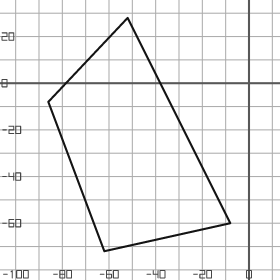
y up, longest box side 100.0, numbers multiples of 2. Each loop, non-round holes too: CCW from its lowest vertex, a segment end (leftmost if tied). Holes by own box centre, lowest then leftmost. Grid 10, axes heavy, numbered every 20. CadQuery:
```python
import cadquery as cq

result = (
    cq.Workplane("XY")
    .moveTo(-62.0, -72.0)
    .lineTo(-8.0, -60.0)
    .lineTo(-52.0, 28.0)
    .lineTo(-86.0, -8.0)
    .close()
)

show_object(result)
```